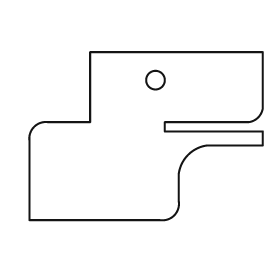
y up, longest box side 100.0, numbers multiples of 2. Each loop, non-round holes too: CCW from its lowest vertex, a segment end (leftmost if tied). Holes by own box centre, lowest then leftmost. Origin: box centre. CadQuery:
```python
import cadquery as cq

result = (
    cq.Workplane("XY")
    .moveTo(-50.0, -36.0)
    .lineTo(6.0, -36.0)
    .threePointArc((12.0, -34.0), (14.0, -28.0))
    .lineTo(14.0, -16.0)
    .threePointArc((18.0, -8.0), (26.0, -4.0))
    .lineTo(50.0, -4.0)
    .lineTo(50.0, 2.0)
    .lineTo(8.0, 2.0)
    .lineTo(8.0, 6.0)
    .lineTo(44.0, 6.0)
    .threePointArc((48.0, 8.0), (50.0, 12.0))
    .lineTo(50.0, 36.0)
    .lineTo(-24.0, 36.0)
    .lineTo(-24.0, 6.0)
    .lineTo(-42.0, 6.0)
    .threePointArc((-48.0, 4.0), (-50.0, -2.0))
    .close()
    .moveTo(4.0, 24.0)
    .circle(4.0)
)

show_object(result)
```